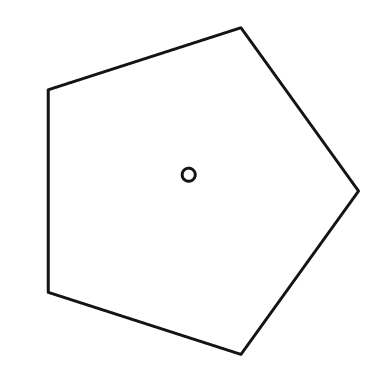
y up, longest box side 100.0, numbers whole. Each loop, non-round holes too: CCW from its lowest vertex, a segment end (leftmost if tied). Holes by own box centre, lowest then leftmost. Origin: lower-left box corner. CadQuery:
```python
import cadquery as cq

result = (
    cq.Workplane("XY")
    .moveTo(59.0, 0.0)
    .lineTo(95.0, 50.0)
    .lineTo(59.0, 100.0)
    .lineTo(0.0, 81.0)
    .lineTo(0.0, 19.0)
    .close()
    .moveTo(43.0, 55.0)
    .circle(2.0)
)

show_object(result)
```